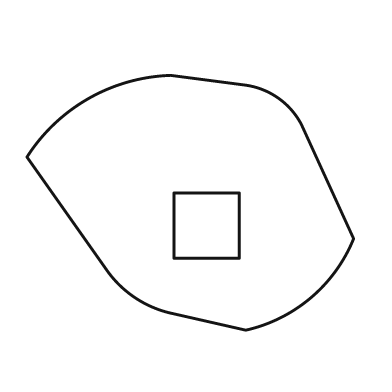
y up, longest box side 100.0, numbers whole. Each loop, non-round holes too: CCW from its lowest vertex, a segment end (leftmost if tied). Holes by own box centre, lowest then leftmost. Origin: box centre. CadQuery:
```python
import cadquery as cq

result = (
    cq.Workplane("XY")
    .moveTo(17.0, -39.0)
    .threePointArc((37.0, -29.0), (50.0, -11.0))
    .lineTo(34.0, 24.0)
    .threePointArc((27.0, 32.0), (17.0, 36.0))
    .lineTo(-6.0, 39.0)
    .threePointArc((-31.0, 32.0), (-50.0, 14.0))
    .lineTo(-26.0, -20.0)
    .threePointArc((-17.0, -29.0), (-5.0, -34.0))
    .close()
    .moveTo(-5.0, -17.0)
    .lineTo(15.0, -17.0)
    .lineTo(15.0, 3.0)
    .lineTo(-5.0, 3.0)
    .close()
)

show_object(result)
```